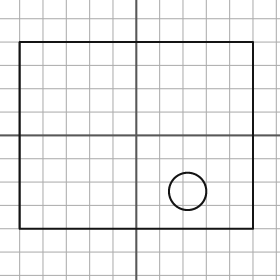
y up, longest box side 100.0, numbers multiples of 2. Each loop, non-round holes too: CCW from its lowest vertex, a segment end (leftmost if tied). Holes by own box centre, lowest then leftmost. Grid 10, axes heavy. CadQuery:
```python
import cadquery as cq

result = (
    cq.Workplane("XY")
    .moveTo(-50.0, -40.0)
    .lineTo(50.0, -40.0)
    .lineTo(50.0, 40.0)
    .lineTo(-50.0, 40.0)
    .close()
    .moveTo(22.0, -24.0)
    .circle(8.0)
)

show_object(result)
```